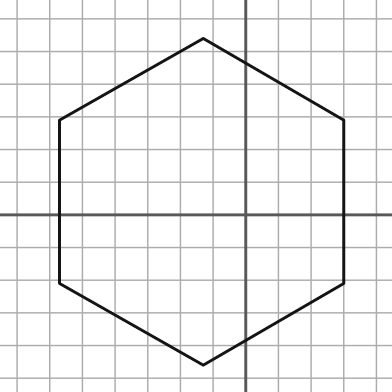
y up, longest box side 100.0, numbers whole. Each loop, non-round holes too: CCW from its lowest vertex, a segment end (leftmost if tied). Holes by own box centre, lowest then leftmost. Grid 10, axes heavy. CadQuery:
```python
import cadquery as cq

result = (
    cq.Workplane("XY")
    .moveTo(-13.0, -46.0)
    .lineTo(30.0, -21.0)
    .lineTo(30.0, 29.0)
    .lineTo(-13.0, 54.0)
    .lineTo(-57.0, 29.0)
    .lineTo(-57.0, -21.0)
    .close()
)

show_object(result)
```